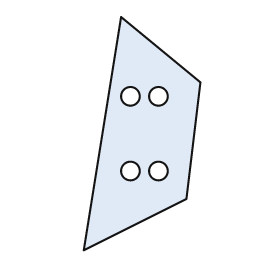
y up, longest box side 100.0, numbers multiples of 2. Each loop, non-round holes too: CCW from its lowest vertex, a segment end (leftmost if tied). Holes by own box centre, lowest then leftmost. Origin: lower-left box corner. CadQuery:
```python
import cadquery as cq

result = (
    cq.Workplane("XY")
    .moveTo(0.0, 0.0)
    .lineTo(44.0, 22.0)
    .lineTo(50.0, 72.0)
    .lineTo(16.0, 100.0)
    .close()
    .moveTo(20.0, 34.0)
    .circle(4.0)
    .moveTo(32.0, 34.0)
    .circle(4.0)
    .moveTo(20.0, 66.0)
    .circle(4.0)
    .moveTo(32.0, 66.0)
    .circle(4.0)
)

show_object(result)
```